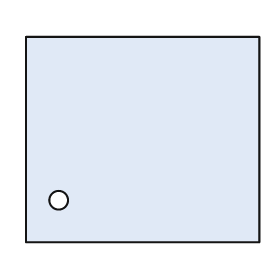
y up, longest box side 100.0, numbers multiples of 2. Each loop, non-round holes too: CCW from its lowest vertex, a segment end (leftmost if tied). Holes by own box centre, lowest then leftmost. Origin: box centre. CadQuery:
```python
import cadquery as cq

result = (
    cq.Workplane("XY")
    .moveTo(-50.0, -44.0)
    .lineTo(50.0, -44.0)
    .lineTo(50.0, 44.0)
    .lineTo(-50.0, 44.0)
    .close()
    .moveTo(-36.0, -26.0)
    .circle(4.0)
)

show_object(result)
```